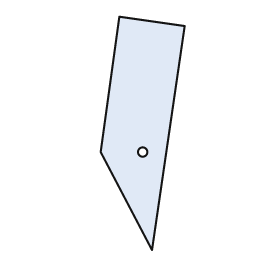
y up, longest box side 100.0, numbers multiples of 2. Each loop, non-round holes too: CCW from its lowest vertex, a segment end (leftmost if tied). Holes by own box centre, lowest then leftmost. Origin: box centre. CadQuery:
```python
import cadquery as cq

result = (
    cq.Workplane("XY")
    .moveTo(4.0, -50.0)
    .lineTo(18.0, 46.0)
    .lineTo(-10.0, 50.0)
    .lineTo(-18.0, -8.0)
    .close()
    .moveTo(0.0, -8.0)
    .circle(2.0)
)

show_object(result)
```